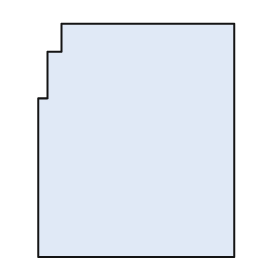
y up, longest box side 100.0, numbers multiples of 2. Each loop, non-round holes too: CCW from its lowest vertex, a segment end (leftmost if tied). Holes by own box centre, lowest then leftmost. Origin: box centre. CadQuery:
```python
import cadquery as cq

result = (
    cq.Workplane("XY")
    .moveTo(-42.0, -50.0)
    .lineTo(42.0, -50.0)
    .lineTo(42.0, 50.0)
    .lineTo(-32.0, 50.0)
    .lineTo(-32.0, 38.0)
    .lineTo(-38.0, 38.0)
    .lineTo(-38.0, 18.0)
    .lineTo(-42.0, 18.0)
    .close()
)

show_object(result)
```